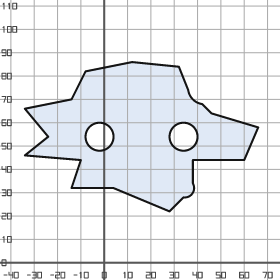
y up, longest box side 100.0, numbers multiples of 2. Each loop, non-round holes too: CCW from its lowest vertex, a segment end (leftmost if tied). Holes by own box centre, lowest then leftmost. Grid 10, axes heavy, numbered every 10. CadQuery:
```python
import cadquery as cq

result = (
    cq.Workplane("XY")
    .moveTo(28.0, 22.0)
    .lineTo(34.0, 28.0)
    .threePointArc((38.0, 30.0), (38.0, 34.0))
    .lineTo(38.0, 44.0)
    .lineTo(60.0, 44.0)
    .lineTo(66.0, 58.0)
    .lineTo(46.0, 64.0)
    .lineTo(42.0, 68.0)
    .threePointArc((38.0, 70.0), (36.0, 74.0))
    .lineTo(32.0, 84.0)
    .lineTo(12.0, 86.0)
    .lineTo(-8.0, 82.0)
    .lineTo(-14.0, 70.0)
    .lineTo(-34.0, 66.0)
    .lineTo(-24.0, 54.0)
    .lineTo(-34.0, 46.0)
    .lineTo(-10.0, 44.0)
    .lineTo(-14.0, 32.0)
    .lineTo(4.0, 32.0)
    .close()
    .moveTo(-2.0, 54.0)
    .circle(6.0)
    .moveTo(34.0, 54.0)
    .circle(6.0)
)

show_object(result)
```